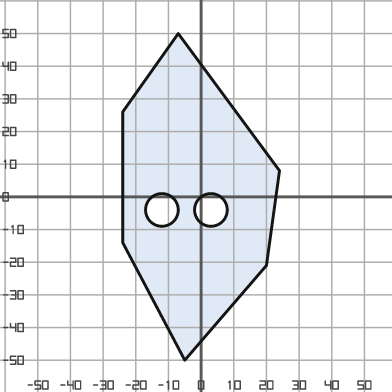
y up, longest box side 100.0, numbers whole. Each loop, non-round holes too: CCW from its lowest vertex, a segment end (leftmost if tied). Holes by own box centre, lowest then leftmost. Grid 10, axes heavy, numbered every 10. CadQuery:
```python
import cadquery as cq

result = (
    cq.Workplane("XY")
    .moveTo(-5.0, -50.0)
    .lineTo(20.0, -21.0)
    .lineTo(24.0, 8.0)
    .lineTo(-7.0, 50.0)
    .lineTo(-24.0, 26.0)
    .lineTo(-24.0, -14.0)
    .close()
    .moveTo(-12.0, -4.0)
    .circle(5.0)
    .moveTo(3.0, -4.0)
    .circle(5.0)
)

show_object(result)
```